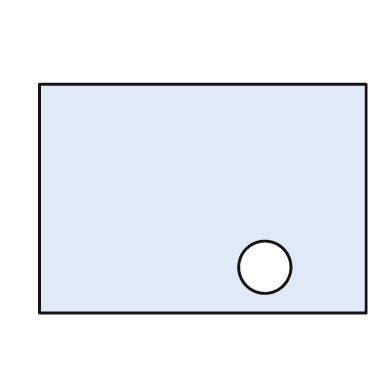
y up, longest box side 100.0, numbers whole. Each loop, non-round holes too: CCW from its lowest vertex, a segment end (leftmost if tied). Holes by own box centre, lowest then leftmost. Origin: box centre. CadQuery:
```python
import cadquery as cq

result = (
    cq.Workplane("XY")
    .moveTo(-50.0, -35.0)
    .lineTo(50.0, -35.0)
    .lineTo(50.0, 35.0)
    .lineTo(-50.0, 35.0)
    .close()
    .moveTo(19.0, -21.0)
    .circle(8.0)
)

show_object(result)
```